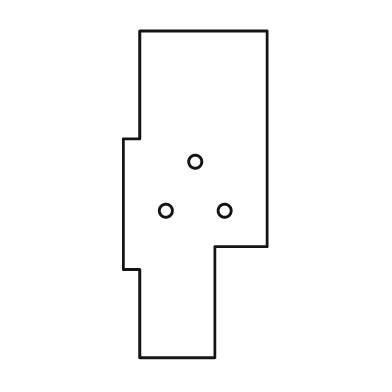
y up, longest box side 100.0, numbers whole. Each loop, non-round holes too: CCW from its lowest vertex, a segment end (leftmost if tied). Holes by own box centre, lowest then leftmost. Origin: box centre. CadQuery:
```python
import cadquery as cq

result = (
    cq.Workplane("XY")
    .moveTo(-17.0, -50.0)
    .lineTo(6.0, -50.0)
    .lineTo(6.0, -16.0)
    .lineTo(22.0, -16.0)
    .lineTo(22.0, 50.0)
    .lineTo(-17.0, 50.0)
    .lineTo(-17.0, 17.0)
    .lineTo(-22.0, 17.0)
    .lineTo(-22.0, -23.0)
    .lineTo(-17.0, -23.0)
    .close()
    .moveTo(-9.0, -5.0)
    .circle(2.0)
    .moveTo(9.0, -5.0)
    .circle(2.0)
    .moveTo(0.0, 10.0)
    .circle(2.0)
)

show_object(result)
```